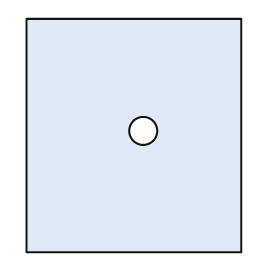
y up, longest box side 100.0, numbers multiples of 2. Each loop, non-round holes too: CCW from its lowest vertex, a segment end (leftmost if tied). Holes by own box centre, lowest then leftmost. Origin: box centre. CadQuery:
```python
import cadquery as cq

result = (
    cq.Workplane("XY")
    .moveTo(-46.0, -50.0)
    .lineTo(46.0, -50.0)
    .lineTo(46.0, 50.0)
    .lineTo(-46.0, 50.0)
    .close()
    .moveTo(4.0, 2.0)
    .circle(6.0)
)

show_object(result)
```